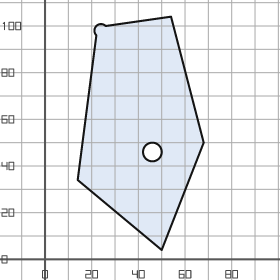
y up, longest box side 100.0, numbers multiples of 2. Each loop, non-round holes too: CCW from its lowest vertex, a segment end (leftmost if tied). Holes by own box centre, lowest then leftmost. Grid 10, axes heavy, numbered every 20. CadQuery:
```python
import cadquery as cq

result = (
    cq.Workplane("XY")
    .moveTo(50.0, 4.0)
    .lineTo(68.0, 50.0)
    .lineTo(54.0, 104.0)
    .lineTo(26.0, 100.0)
    .threePointArc((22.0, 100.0), (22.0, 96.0))
    .lineTo(14.0, 34.0)
    .close()
    .moveTo(46.0, 46.0)
    .circle(4.0)
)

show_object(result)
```